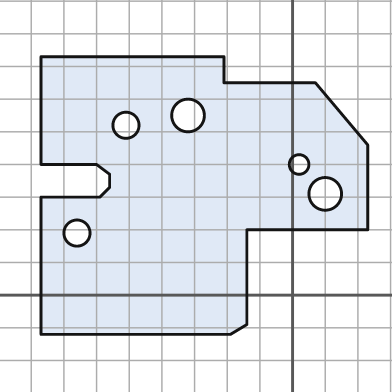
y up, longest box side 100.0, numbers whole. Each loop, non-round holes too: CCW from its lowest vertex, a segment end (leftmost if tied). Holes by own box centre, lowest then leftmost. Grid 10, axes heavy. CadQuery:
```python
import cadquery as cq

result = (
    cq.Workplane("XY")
    .moveTo(-77.0, -12.0)
    .lineTo(-19.0, -12.0)
    .lineTo(-14.0, -9.0)
    .lineTo(-14.0, 20.0)
    .lineTo(23.0, 20.0)
    .lineTo(23.0, 46.0)
    .lineTo(7.0, 65.0)
    .lineTo(-21.0, 65.0)
    .lineTo(-21.0, 73.0)
    .lineTo(-77.0, 73.0)
    .lineTo(-77.0, 40.0)
    .lineTo(-60.0, 40.0)
    .lineTo(-56.0, 37.0)
    .lineTo(-56.0, 33.0)
    .lineTo(-59.0, 30.0)
    .lineTo(-77.0, 30.0)
    .close()
    .moveTo(-66.0, 19.0)
    .circle(4.0)
    .moveTo(10.0, 31.0)
    .circle(5.0)
    .moveTo(2.0, 40.0)
    .circle(3.0)
    .moveTo(-51.0, 52.0)
    .circle(4.0)
    .moveTo(-32.0, 55.0)
    .circle(5.0)
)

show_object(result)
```